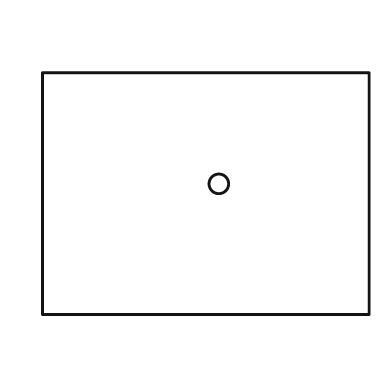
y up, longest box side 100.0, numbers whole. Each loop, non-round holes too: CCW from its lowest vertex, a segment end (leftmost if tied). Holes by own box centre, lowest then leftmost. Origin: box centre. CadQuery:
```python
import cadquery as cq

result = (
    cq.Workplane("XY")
    .moveTo(-50.0, -37.0)
    .lineTo(50.0, -37.0)
    .lineTo(50.0, 37.0)
    .lineTo(-50.0, 37.0)
    .close()
    .moveTo(4.0, 3.0)
    .circle(3.0)
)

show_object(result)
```